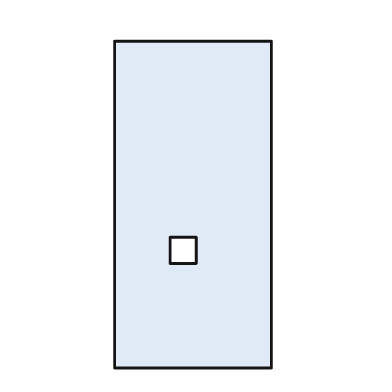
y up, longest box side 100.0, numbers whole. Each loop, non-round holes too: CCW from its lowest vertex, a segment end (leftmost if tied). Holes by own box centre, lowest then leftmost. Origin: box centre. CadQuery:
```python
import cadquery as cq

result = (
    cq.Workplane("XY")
    .moveTo(-24.0, -50.0)
    .lineTo(24.0, -50.0)
    .lineTo(24.0, 50.0)
    .lineTo(-24.0, 50.0)
    .close()
    .moveTo(-7.0, -18.0)
    .lineTo(1.0, -18.0)
    .lineTo(1.0, -10.0)
    .lineTo(-7.0, -10.0)
    .close()
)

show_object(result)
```